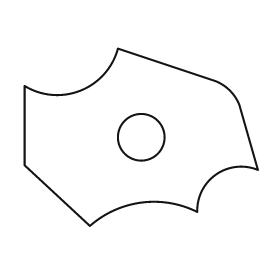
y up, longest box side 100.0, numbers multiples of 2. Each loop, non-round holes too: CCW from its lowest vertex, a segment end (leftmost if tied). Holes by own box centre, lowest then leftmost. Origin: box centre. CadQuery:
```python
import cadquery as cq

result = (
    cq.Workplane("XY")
    .moveTo(-22.0, -38.0)
    .threePointArc((0.0, -28.0), (24.0, -32.0))
    .threePointArc((32.0, -16.0), (50.0, -14.0))
    .lineTo(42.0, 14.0)
    .threePointArc((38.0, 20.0), (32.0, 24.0))
    .lineTo(-10.0, 38.0)
    .threePointArc((-26.0, 20.0), (-50.0, 22.0))
    .lineTo(-50.0, -12.0)
    .close()
    .moveTo(0.0, 0.0)
    .circle(10.0)
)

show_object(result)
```